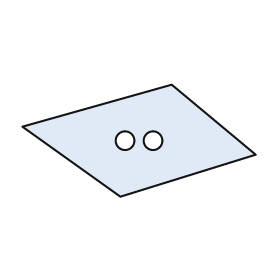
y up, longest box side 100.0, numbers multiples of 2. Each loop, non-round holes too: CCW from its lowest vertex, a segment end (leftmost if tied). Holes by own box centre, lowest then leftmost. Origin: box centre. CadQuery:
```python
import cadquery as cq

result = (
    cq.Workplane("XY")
    .moveTo(-8.0, -24.0)
    .lineTo(50.0, -6.0)
    .lineTo(14.0, 24.0)
    .lineTo(-50.0, 6.0)
    .close()
    .moveTo(-6.0, 0.0)
    .circle(4.0)
    .moveTo(6.0, 0.0)
    .circle(4.0)
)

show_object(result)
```